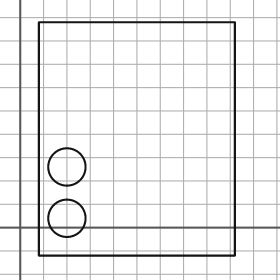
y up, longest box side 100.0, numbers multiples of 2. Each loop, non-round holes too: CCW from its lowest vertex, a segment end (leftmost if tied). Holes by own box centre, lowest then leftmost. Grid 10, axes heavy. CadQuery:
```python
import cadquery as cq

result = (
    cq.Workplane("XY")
    .moveTo(8.0, -12.0)
    .lineTo(92.0, -12.0)
    .lineTo(92.0, 88.0)
    .lineTo(8.0, 88.0)
    .close()
    .moveTo(20.0, 4.0)
    .circle(8.0)
    .moveTo(20.0, 26.0)
    .circle(8.0)
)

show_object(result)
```